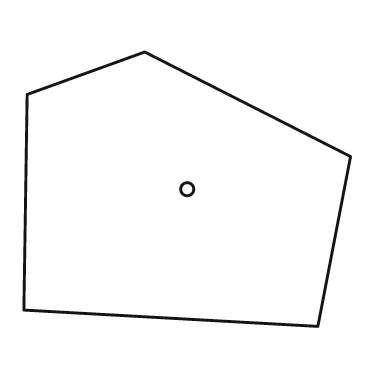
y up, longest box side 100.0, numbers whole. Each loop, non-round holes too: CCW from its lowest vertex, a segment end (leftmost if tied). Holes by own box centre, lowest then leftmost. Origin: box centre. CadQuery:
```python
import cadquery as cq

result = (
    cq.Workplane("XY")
    .moveTo(40.0, -42.0)
    .lineTo(50.0, 10.0)
    .lineTo(-13.0, 42.0)
    .lineTo(-49.0, 29.0)
    .lineTo(-50.0, -37.0)
    .close()
    .moveTo(0.0, 0.0)
    .circle(2.0)
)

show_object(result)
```